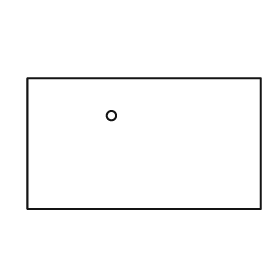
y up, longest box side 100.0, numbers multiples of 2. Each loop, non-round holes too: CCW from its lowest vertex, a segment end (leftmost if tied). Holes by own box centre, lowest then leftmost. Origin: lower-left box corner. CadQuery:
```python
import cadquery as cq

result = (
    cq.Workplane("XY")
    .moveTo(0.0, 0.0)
    .lineTo(100.0, 0.0)
    .lineTo(100.0, 56.0)
    .lineTo(0.0, 56.0)
    .close()
    .moveTo(36.0, 40.0)
    .circle(2.0)
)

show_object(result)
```